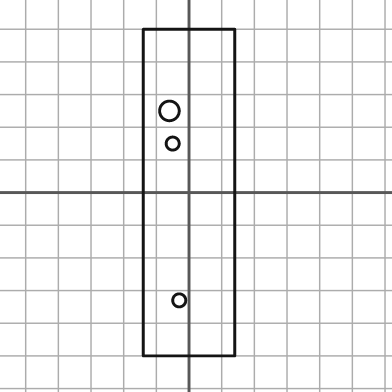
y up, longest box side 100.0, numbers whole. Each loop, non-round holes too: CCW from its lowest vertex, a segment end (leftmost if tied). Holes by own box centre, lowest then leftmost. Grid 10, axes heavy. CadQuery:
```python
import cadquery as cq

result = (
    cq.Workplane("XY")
    .moveTo(-14.0, -50.0)
    .lineTo(14.0, -50.0)
    .lineTo(14.0, 50.0)
    .lineTo(-14.0, 50.0)
    .close()
    .moveTo(-3.0, -33.0)
    .circle(2.0)
    .moveTo(-5.0, 15.0)
    .circle(2.0)
    .moveTo(-6.0, 25.0)
    .circle(3.0)
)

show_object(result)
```